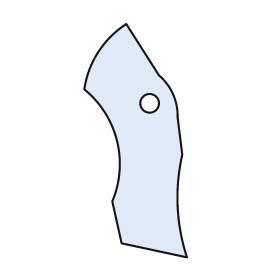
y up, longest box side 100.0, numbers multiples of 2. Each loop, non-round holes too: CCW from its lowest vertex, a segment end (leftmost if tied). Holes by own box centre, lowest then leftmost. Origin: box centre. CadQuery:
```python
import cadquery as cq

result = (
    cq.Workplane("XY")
    .moveTo(22.0, -50.0)
    .threePointArc((18.0, -28.0), (20.0, -6.0))
    .lineTo(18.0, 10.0)
    .threePointArc((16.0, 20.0), (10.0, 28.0))
    .lineTo(-4.0, 50.0)
    .threePointArc((-16.0, 38.0), (-22.0, 22.0))
    .threePointArc((-8.0, 0.0), (-10.0, -26.0))
    .lineTo(-6.0, -44.0)
    .close()
    .moveTo(6.0, 16.0)
    .circle(4.0)
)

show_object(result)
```